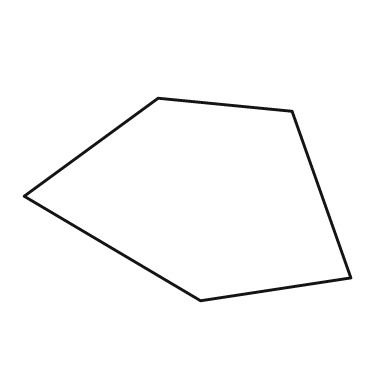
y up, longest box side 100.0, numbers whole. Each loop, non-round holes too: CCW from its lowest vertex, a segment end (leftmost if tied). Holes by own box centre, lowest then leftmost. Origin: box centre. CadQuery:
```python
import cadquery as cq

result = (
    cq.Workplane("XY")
    .moveTo(4.0, -31.0)
    .lineTo(50.0, -24.0)
    .lineTo(32.0, 27.0)
    .lineTo(-9.0, 31.0)
    .lineTo(-50.0, 1.0)
    .close()
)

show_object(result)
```